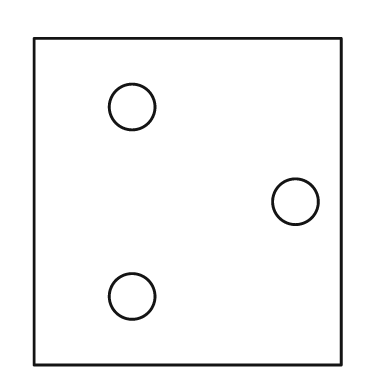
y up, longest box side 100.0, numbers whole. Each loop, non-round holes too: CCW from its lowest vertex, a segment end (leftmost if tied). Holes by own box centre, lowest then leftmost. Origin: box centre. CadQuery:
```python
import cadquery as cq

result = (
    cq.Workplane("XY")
    .moveTo(-47.0, -50.0)
    .lineTo(47.0, -50.0)
    .lineTo(47.0, 50.0)
    .lineTo(-47.0, 50.0)
    .close()
    .moveTo(-17.0, -29.0)
    .circle(7.0)
    .moveTo(33.0, 0.0)
    .circle(7.0)
    .moveTo(-17.0, 29.0)
    .circle(7.0)
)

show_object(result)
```